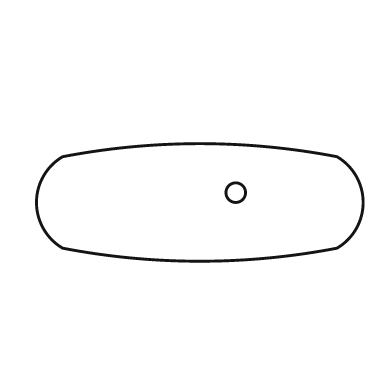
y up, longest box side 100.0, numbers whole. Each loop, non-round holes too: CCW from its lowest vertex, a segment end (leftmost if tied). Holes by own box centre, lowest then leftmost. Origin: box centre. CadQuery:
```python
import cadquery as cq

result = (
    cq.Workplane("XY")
    .moveTo(-42.0, -14.0)
    .threePointArc((0.0, -18.0), (42.0, -14.0))
    .threePointArc((50.0, 0.0), (42.0, 14.0))
    .threePointArc((0.0, 18.0), (-42.0, 14.0))
    .threePointArc((-50.0, 0.0), (-42.0, -14.0))
    .close()
    .moveTo(11.0, 3.0)
    .circle(3.0)
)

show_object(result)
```